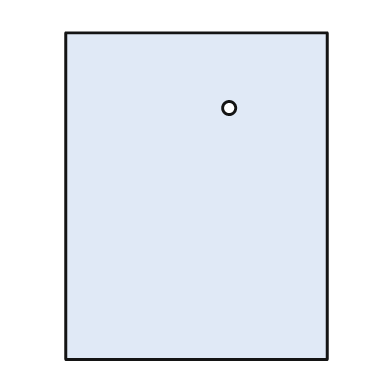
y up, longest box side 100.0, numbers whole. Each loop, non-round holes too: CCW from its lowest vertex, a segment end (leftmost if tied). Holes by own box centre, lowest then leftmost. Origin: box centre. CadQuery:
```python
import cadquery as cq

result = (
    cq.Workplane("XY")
    .moveTo(-40.0, -50.0)
    .lineTo(40.0, -50.0)
    .lineTo(40.0, 50.0)
    .lineTo(-40.0, 50.0)
    .close()
    .moveTo(10.0, 27.0)
    .circle(2.0)
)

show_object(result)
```